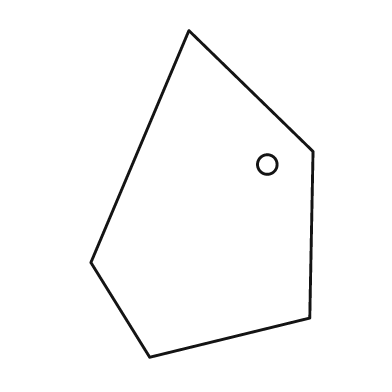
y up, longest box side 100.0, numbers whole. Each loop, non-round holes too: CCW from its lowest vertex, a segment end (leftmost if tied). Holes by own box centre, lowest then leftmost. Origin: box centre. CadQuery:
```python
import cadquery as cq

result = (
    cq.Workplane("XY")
    .moveTo(-16.0, -50.0)
    .lineTo(33.0, -38.0)
    .lineTo(34.0, 13.0)
    .lineTo(-4.0, 50.0)
    .lineTo(-34.0, -21.0)
    .close()
    .moveTo(20.0, 9.0)
    .circle(3.0)
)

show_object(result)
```